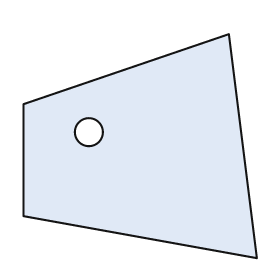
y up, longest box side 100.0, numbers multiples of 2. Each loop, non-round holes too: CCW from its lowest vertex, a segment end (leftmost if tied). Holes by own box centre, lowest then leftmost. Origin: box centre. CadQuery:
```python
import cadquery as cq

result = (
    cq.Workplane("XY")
    .moveTo(50.0, -48.0)
    .lineTo(38.0, 48.0)
    .lineTo(-50.0, 18.0)
    .lineTo(-50.0, -30.0)
    .close()
    .moveTo(-22.0, 6.0)
    .circle(6.0)
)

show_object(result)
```